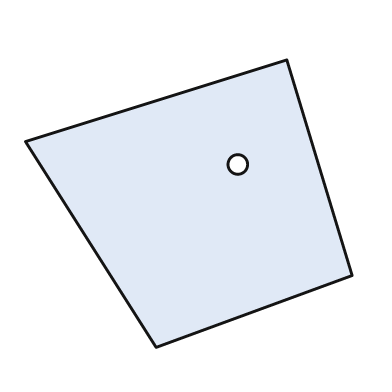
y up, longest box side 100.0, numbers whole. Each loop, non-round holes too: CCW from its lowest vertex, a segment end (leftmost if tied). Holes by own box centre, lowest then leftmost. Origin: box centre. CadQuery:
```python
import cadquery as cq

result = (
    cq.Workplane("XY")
    .moveTo(-10.0, -44.0)
    .lineTo(50.0, -22.0)
    .lineTo(30.0, 44.0)
    .lineTo(-50.0, 19.0)
    .close()
    .moveTo(15.0, 12.0)
    .circle(3.0)
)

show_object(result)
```